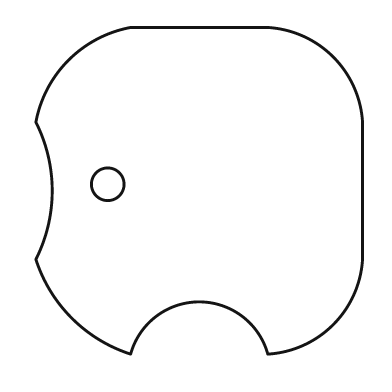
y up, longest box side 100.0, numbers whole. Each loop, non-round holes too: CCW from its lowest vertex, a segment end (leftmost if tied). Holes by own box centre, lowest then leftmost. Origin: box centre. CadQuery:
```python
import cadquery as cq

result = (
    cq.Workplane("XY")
    .moveTo(-21.0, -50.0)
    .threePointArc((0.0, -34.0), (21.0, -50.0))
    .threePointArc((41.0, -41.0), (50.0, -21.0))
    .lineTo(50.0, 21.0)
    .threePointArc((41.0, 41.0), (21.0, 50.0))
    .lineTo(-21.0, 50.0)
    .threePointArc((-40.0, 40.0), (-50.0, 21.0))
    .threePointArc((-45.0, 0.0), (-50.0, -21.0))
    .threePointArc((-39.0, -39.0), (-21.0, -50.0))
    .close()
    .moveTo(-28.0, 2.0)
    .circle(5.0)
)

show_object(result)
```